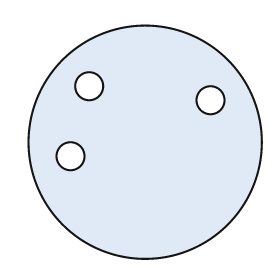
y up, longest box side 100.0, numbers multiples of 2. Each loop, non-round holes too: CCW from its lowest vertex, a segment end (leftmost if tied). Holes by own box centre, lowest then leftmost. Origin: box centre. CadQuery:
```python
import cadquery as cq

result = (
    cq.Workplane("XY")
    .moveTo(0.0, 0.0)
    .circle(50.0)
    .moveTo(-32.0, -6.0)
    .circle(6.0)
    .moveTo(28.0, 18.0)
    .circle(6.0)
    .moveTo(-24.0, 24.0)
    .circle(6.0)
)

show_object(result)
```